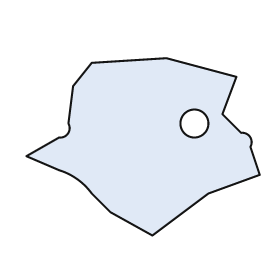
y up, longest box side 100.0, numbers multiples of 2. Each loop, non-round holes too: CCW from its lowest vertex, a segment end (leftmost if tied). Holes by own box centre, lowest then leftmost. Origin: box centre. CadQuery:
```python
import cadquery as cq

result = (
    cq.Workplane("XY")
    .moveTo(4.0, -38.0)
    .lineTo(28.0, -20.0)
    .lineTo(50.0, -12.0)
    .lineTo(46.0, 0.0)
    .threePointArc((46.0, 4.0), (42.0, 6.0))
    .lineTo(34.0, 14.0)
    .lineTo(40.0, 30.0)
    .lineTo(10.0, 38.0)
    .lineTo(-22.0, 36.0)
    .lineTo(-30.0, 26.0)
    .lineTo(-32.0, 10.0)
    .threePointArc((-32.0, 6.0), (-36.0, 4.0))
    .lineTo(-50.0, -4.0)
    .lineTo(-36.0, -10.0)
    .threePointArc((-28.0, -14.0), (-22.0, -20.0))
    .lineTo(-14.0, -28.0)
    .close()
    .moveTo(22.0, 10.0)
    .circle(6.0)
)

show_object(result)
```